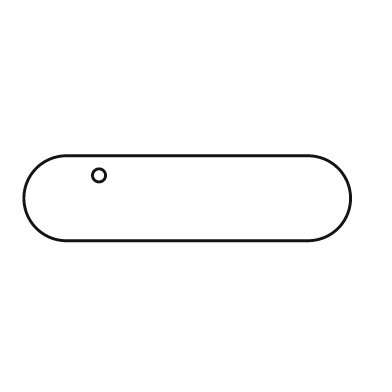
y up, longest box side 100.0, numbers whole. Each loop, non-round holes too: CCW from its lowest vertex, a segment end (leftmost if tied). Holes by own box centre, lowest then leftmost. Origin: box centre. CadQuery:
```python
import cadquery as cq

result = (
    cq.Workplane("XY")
    .moveTo(-37.0, -13.0)
    .lineTo(37.0, -13.0)
    .threePointArc((50.0, 0.0), (37.0, 13.0))
    .lineTo(-37.0, 13.0)
    .threePointArc((-50.0, 0.0), (-37.0, -13.0))
    .close()
    .moveTo(-27.0, 7.0)
    .circle(2.0)
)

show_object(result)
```